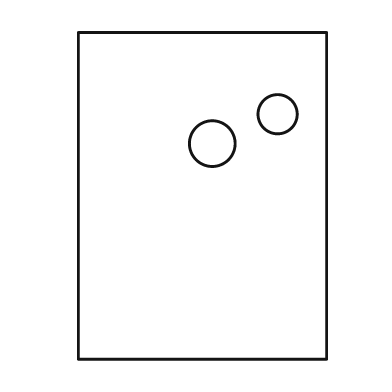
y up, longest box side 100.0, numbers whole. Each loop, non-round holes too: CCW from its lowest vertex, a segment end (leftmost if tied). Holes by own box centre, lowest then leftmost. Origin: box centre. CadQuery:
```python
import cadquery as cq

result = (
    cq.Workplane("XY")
    .moveTo(-38.0, -50.0)
    .lineTo(38.0, -50.0)
    .lineTo(38.0, 50.0)
    .lineTo(-38.0, 50.0)
    .close()
    .moveTo(3.0, 16.0)
    .circle(7.0)
    .moveTo(23.0, 25.0)
    .circle(6.0)
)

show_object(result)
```